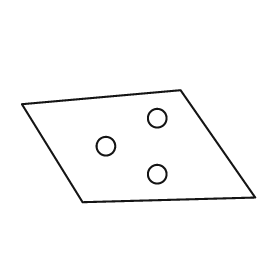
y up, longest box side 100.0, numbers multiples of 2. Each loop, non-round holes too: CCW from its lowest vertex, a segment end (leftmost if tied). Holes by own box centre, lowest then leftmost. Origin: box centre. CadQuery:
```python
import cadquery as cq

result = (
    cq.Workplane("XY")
    .moveTo(-24.0, -24.0)
    .lineTo(50.0, -22.0)
    .lineTo(18.0, 24.0)
    .lineTo(-50.0, 18.0)
    .close()
    .moveTo(8.0, -12.0)
    .circle(4.0)
    .moveTo(-14.0, 0.0)
    .circle(4.0)
    .moveTo(8.0, 12.0)
    .circle(4.0)
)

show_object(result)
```